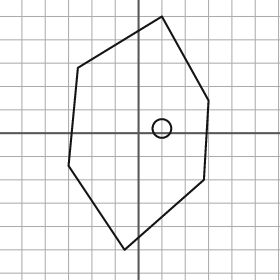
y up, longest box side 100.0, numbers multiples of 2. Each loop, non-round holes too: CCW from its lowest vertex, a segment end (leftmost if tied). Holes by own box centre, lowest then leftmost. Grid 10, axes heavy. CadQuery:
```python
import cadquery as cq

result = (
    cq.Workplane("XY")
    .moveTo(-6.0, -50.0)
    .lineTo(28.0, -20.0)
    .lineTo(30.0, 14.0)
    .lineTo(10.0, 50.0)
    .lineTo(-26.0, 28.0)
    .lineTo(-30.0, -14.0)
    .close()
    .moveTo(10.0, 2.0)
    .circle(4.0)
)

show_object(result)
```